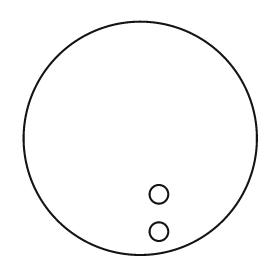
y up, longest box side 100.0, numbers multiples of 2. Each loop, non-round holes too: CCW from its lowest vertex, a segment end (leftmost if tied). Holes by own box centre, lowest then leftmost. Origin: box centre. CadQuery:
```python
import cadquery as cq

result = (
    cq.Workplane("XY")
    .moveTo(0.0, 0.0)
    .circle(50.0)
    .moveTo(8.0, -40.0)
    .circle(4.0)
    .moveTo(8.0, -24.0)
    .circle(4.0)
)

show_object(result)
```